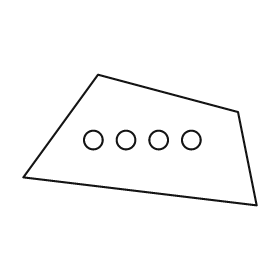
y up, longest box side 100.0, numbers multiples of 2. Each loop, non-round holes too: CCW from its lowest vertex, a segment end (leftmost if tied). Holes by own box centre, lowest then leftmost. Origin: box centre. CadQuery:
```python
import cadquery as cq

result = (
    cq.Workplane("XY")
    .moveTo(50.0, -28.0)
    .lineTo(42.0, 12.0)
    .lineTo(-18.0, 28.0)
    .lineTo(-50.0, -16.0)
    .close()
    .moveTo(-20.0, 0.0)
    .circle(4.0)
    .moveTo(-6.0, 0.0)
    .circle(4.0)
    .moveTo(8.0, 0.0)
    .circle(4.0)
    .moveTo(22.0, 0.0)
    .circle(4.0)
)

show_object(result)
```